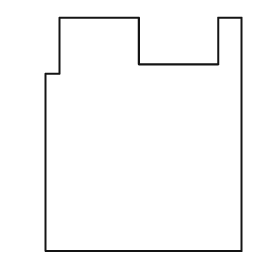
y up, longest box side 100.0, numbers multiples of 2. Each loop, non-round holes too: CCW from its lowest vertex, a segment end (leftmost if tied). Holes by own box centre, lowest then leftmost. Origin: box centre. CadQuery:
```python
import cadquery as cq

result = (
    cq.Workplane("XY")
    .moveTo(-42.0, -50.0)
    .lineTo(42.0, -50.0)
    .lineTo(42.0, 50.0)
    .lineTo(32.0, 50.0)
    .lineTo(32.0, 30.0)
    .lineTo(-2.0, 30.0)
    .lineTo(-2.0, 50.0)
    .lineTo(-36.0, 50.0)
    .lineTo(-36.0, 26.0)
    .lineTo(-42.0, 26.0)
    .close()
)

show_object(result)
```